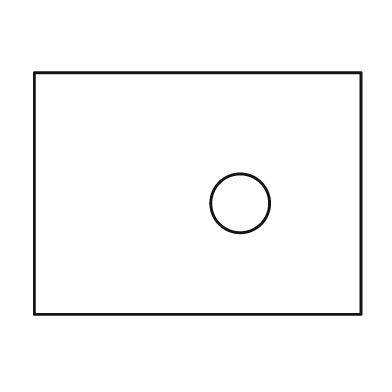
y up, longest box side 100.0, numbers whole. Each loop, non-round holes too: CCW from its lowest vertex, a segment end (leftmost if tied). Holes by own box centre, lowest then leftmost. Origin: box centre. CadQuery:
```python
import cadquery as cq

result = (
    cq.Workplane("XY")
    .moveTo(-50.0, -37.0)
    .lineTo(50.0, -37.0)
    .lineTo(50.0, 37.0)
    .lineTo(-50.0, 37.0)
    .close()
    .moveTo(13.0, -3.0)
    .circle(9.0)
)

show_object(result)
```